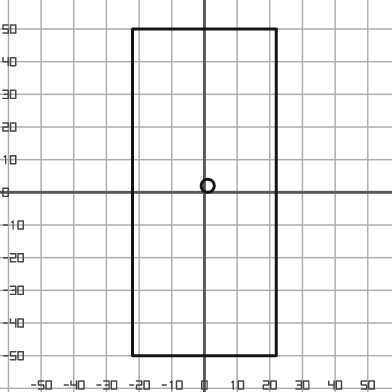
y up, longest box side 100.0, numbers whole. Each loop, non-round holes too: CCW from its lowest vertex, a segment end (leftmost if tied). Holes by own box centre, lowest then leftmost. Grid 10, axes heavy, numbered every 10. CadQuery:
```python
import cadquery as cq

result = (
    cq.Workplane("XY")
    .moveTo(-22.0, -50.0)
    .lineTo(22.0, -50.0)
    .lineTo(22.0, 50.0)
    .lineTo(-22.0, 50.0)
    .close()
    .moveTo(1.0, 2.0)
    .circle(2.0)
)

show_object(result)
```